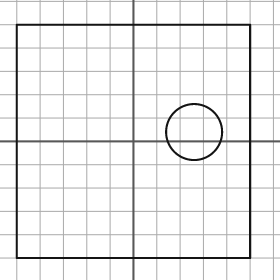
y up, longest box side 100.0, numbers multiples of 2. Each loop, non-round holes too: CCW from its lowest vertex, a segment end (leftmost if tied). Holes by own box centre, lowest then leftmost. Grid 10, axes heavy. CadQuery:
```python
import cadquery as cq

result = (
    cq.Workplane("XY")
    .moveTo(-50.0, -50.0)
    .lineTo(50.0, -50.0)
    .lineTo(50.0, 50.0)
    .lineTo(-50.0, 50.0)
    .close()
    .moveTo(26.0, 4.0)
    .circle(12.0)
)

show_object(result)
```